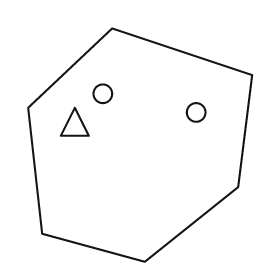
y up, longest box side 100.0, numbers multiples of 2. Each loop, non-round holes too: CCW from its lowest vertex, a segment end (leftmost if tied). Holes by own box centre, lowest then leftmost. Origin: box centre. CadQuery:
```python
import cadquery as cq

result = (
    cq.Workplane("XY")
    .moveTo(2.0, -50.0)
    .lineTo(42.0, -18.0)
    .lineTo(48.0, 30.0)
    .lineTo(-12.0, 50.0)
    .lineTo(-48.0, 16.0)
    .lineTo(-42.0, -38.0)
    .close()
    .moveTo(-34.0, 4.0)
    .lineTo(-22.0, 4.0)
    .lineTo(-28.0, 16.0)
    .close()
    .moveTo(24.0, 14.0)
    .circle(4.0)
    .moveTo(-16.0, 22.0)
    .circle(4.0)
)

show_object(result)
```